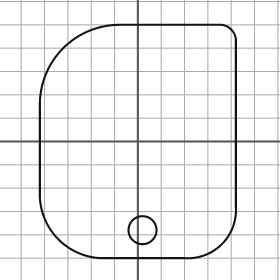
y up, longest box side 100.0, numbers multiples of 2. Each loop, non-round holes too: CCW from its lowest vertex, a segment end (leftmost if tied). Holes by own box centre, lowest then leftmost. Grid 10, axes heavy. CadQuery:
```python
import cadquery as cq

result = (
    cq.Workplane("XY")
    .moveTo(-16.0, -50.0)
    .lineTo(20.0, -50.0)
    .threePointArc((36.0, -44.0), (42.0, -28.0))
    .lineTo(42.0, 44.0)
    .threePointArc((40.0, 48.0), (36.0, 50.0))
    .lineTo(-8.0, 50.0)
    .threePointArc((-32.0, 40.0), (-42.0, 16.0))
    .lineTo(-42.0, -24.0)
    .threePointArc((-34.0, -42.0), (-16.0, -50.0))
    .close()
    .moveTo(2.0, -38.0)
    .circle(6.0)
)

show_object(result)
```